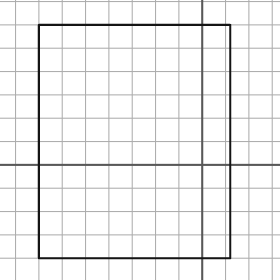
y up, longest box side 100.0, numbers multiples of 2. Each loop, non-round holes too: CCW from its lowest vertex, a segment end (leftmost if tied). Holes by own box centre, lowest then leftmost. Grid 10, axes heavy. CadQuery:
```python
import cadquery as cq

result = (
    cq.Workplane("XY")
    .moveTo(-70.0, -40.0)
    .lineTo(12.0, -40.0)
    .lineTo(12.0, 60.0)
    .lineTo(-70.0, 60.0)
    .close()
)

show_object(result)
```